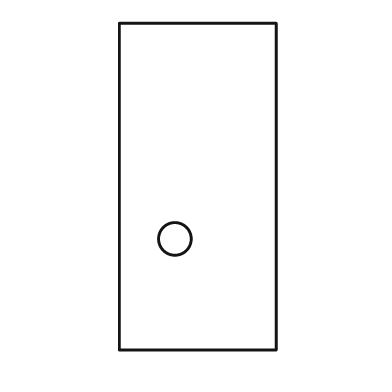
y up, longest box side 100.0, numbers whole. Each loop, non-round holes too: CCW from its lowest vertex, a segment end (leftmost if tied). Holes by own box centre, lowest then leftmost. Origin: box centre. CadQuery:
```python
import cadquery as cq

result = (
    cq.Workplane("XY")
    .moveTo(-24.0, -50.0)
    .lineTo(24.0, -50.0)
    .lineTo(24.0, 50.0)
    .lineTo(-24.0, 50.0)
    .close()
    .moveTo(-7.0, -16.0)
    .circle(5.0)
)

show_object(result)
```